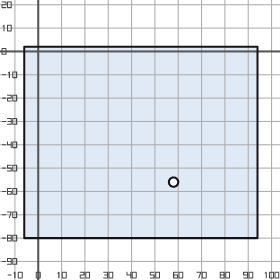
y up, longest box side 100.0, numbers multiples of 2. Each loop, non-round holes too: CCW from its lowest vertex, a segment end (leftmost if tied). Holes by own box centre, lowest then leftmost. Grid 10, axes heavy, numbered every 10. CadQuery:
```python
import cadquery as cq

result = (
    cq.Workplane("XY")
    .moveTo(-6.0, -80.0)
    .lineTo(94.0, -80.0)
    .lineTo(94.0, 2.0)
    .lineTo(-6.0, 2.0)
    .close()
    .moveTo(58.0, -56.0)
    .circle(2.0)
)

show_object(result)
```